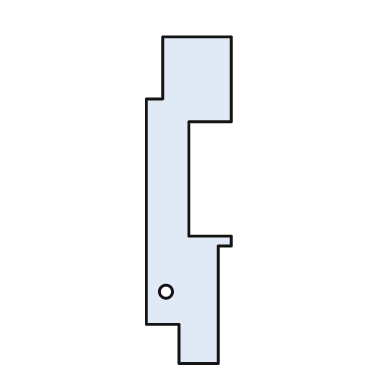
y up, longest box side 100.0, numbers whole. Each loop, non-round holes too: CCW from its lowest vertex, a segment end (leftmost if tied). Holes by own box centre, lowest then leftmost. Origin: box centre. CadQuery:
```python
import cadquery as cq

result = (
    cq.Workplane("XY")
    .moveTo(-3.0, -50.0)
    .lineTo(9.0, -50.0)
    .lineTo(9.0, -14.0)
    .lineTo(13.0, -14.0)
    .lineTo(13.0, -11.0)
    .lineTo(0.0, -11.0)
    .lineTo(0.0, 24.0)
    .lineTo(13.0, 24.0)
    .lineTo(13.0, 50.0)
    .lineTo(-8.0, 50.0)
    .lineTo(-8.0, 31.0)
    .lineTo(-13.0, 31.0)
    .lineTo(-13.0, -38.0)
    .lineTo(-3.0, -38.0)
    .close()
    .moveTo(-7.0, -28.0)
    .circle(2.0)
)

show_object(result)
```